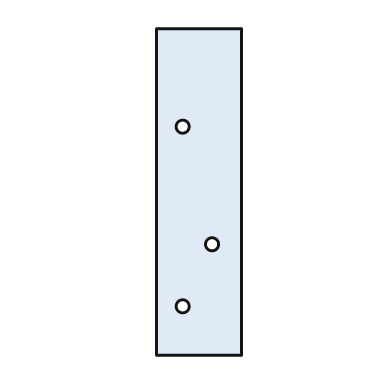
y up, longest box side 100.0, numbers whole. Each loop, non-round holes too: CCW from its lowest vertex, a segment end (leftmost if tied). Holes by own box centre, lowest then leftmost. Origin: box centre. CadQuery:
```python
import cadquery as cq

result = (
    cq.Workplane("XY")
    .moveTo(-13.0, -50.0)
    .lineTo(13.0, -50.0)
    .lineTo(13.0, 50.0)
    .lineTo(-13.0, 50.0)
    .close()
    .moveTo(-5.0, -35.0)
    .circle(2.0)
    .moveTo(4.0, -16.0)
    .circle(2.0)
    .moveTo(-5.0, 20.0)
    .circle(2.0)
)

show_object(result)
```